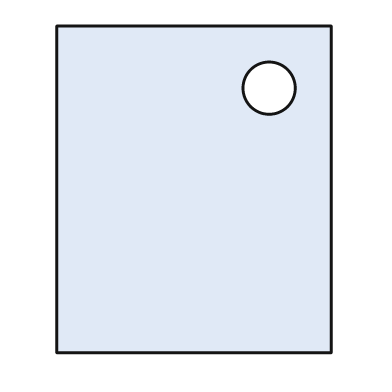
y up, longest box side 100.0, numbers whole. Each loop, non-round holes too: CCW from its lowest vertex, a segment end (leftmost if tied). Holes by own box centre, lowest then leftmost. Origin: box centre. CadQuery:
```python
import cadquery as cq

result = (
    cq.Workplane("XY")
    .moveTo(-42.0, -50.0)
    .lineTo(42.0, -50.0)
    .lineTo(42.0, 50.0)
    .lineTo(-42.0, 50.0)
    .close()
    .moveTo(23.0, 31.0)
    .circle(8.0)
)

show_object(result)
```